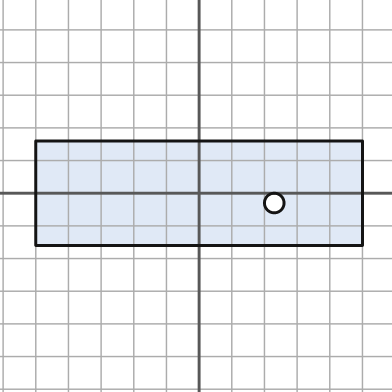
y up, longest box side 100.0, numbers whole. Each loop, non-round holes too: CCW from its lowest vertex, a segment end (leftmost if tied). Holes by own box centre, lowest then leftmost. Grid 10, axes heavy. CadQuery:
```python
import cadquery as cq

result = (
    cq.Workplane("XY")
    .moveTo(-50.0, -16.0)
    .lineTo(50.0, -16.0)
    .lineTo(50.0, 16.0)
    .lineTo(-50.0, 16.0)
    .close()
    .moveTo(23.0, -3.0)
    .circle(3.0)
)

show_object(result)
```